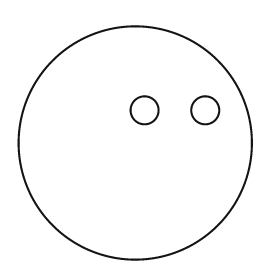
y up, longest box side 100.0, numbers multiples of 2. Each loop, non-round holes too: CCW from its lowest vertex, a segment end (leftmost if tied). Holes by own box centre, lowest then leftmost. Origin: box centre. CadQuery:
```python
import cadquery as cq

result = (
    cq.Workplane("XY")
    .moveTo(0.0, 0.0)
    .circle(50.0)
    .moveTo(4.0, 14.0)
    .circle(6.0)
    .moveTo(30.0, 14.0)
    .circle(6.0)
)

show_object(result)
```